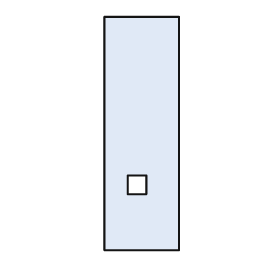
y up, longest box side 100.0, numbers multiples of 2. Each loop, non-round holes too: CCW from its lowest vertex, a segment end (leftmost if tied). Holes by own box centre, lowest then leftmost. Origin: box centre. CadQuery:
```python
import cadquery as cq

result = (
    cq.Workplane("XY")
    .moveTo(-16.0, -50.0)
    .lineTo(16.0, -50.0)
    .lineTo(16.0, 50.0)
    .lineTo(-16.0, 50.0)
    .close()
    .moveTo(-6.0, -26.0)
    .lineTo(2.0, -26.0)
    .lineTo(2.0, -18.0)
    .lineTo(-6.0, -18.0)
    .close()
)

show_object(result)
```